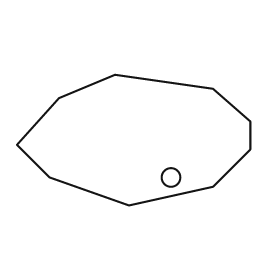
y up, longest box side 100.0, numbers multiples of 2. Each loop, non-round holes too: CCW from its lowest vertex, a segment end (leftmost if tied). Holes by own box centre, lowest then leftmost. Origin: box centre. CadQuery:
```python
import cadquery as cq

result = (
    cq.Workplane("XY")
    .moveTo(-2.0, -28.0)
    .lineTo(34.0, -20.0)
    .lineTo(50.0, -4.0)
    .lineTo(50.0, 8.0)
    .lineTo(34.0, 22.0)
    .lineTo(-8.0, 28.0)
    .lineTo(-32.0, 18.0)
    .lineTo(-50.0, -2.0)
    .lineTo(-36.0, -16.0)
    .close()
    .moveTo(16.0, -16.0)
    .circle(4.0)
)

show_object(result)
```